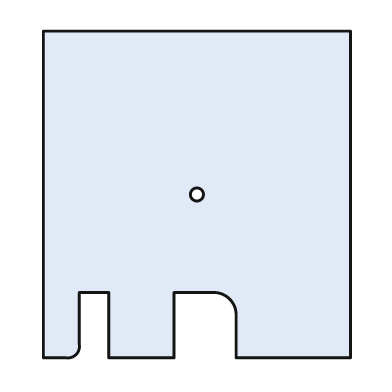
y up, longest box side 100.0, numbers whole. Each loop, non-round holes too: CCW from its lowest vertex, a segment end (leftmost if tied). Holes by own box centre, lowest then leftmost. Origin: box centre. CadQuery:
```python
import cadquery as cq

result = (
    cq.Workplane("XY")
    .moveTo(-47.0, -50.0)
    .lineTo(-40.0, -50.0)
    .threePointArc((-37.0, -49.0), (-36.0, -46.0))
    .lineTo(-36.0, -30.0)
    .lineTo(-27.0, -30.0)
    .lineTo(-27.0, -50.0)
    .lineTo(-7.0, -50.0)
    .lineTo(-7.0, -30.0)
    .lineTo(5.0, -30.0)
    .threePointArc((10.0, -32.0), (12.0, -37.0))
    .lineTo(12.0, -50.0)
    .lineTo(47.0, -50.0)
    .lineTo(47.0, 50.0)
    .lineTo(-47.0, 50.0)
    .close()
    .moveTo(0.0, 0.0)
    .circle(2.0)
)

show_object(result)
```